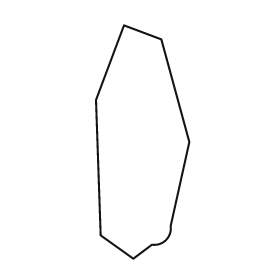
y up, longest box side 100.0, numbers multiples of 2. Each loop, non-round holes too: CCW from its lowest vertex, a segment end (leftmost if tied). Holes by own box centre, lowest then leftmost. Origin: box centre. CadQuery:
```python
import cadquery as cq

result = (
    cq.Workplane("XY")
    .moveTo(-4.0, -50.0)
    .lineTo(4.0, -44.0)
    .threePointArc((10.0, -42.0), (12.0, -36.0))
    .lineTo(20.0, 0.0)
    .lineTo(8.0, 44.0)
    .lineTo(-8.0, 50.0)
    .lineTo(-20.0, 18.0)
    .lineTo(-18.0, -40.0)
    .close()
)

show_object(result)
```